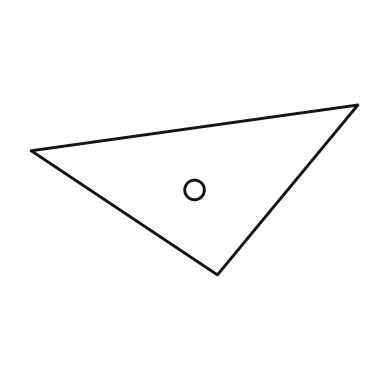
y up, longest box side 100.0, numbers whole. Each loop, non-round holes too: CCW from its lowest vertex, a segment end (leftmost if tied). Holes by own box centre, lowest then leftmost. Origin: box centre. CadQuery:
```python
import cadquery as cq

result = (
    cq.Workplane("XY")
    .moveTo(7.0, -26.0)
    .lineTo(50.0, 26.0)
    .lineTo(-50.0, 12.0)
    .close()
    .moveTo(0.0, 0.0)
    .circle(3.0)
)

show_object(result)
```